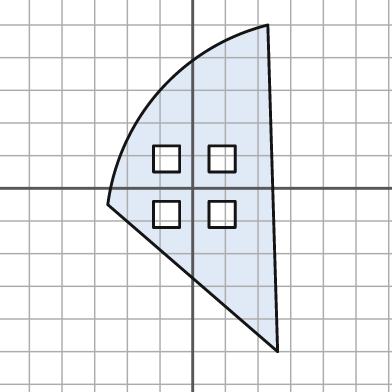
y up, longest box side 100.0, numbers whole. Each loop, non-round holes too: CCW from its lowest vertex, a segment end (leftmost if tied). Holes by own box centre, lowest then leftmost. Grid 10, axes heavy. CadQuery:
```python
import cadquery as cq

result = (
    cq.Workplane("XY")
    .moveTo(26.0, -50.0)
    .lineTo(23.0, 50.0)
    .threePointArc((-10.0, 30.0), (-26.0, -5.0))
    .close()
    .moveTo(-12.0, -12.0)
    .lineTo(-4.0, -12.0)
    .lineTo(-4.0, -4.0)
    .lineTo(-12.0, -4.0)
    .close()
    .moveTo(5.0, -12.0)
    .lineTo(13.0, -12.0)
    .lineTo(13.0, -4.0)
    .lineTo(5.0, -4.0)
    .close()
    .moveTo(-12.0, 5.0)
    .lineTo(-4.0, 5.0)
    .lineTo(-4.0, 13.0)
    .lineTo(-12.0, 13.0)
    .close()
    .moveTo(5.0, 5.0)
    .lineTo(13.0, 5.0)
    .lineTo(13.0, 13.0)
    .lineTo(5.0, 13.0)
    .close()
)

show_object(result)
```